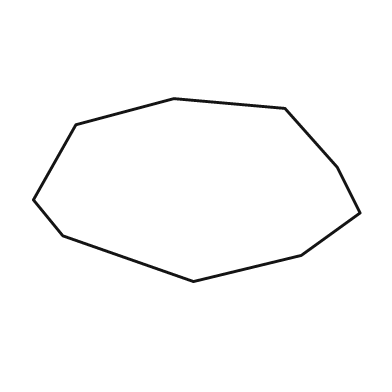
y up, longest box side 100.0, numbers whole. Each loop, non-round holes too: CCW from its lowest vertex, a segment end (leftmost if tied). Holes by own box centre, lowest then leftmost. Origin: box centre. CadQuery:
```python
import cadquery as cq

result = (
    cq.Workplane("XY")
    .moveTo(-1.0, -28.0)
    .lineTo(32.0, -20.0)
    .lineTo(50.0, -7.0)
    .lineTo(43.0, 7.0)
    .lineTo(27.0, 25.0)
    .lineTo(-7.0, 28.0)
    .lineTo(-37.0, 20.0)
    .lineTo(-50.0, -3.0)
    .lineTo(-41.0, -14.0)
    .close()
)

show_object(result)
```